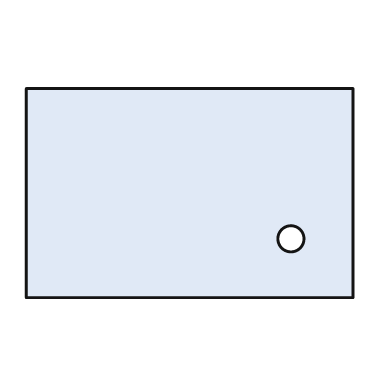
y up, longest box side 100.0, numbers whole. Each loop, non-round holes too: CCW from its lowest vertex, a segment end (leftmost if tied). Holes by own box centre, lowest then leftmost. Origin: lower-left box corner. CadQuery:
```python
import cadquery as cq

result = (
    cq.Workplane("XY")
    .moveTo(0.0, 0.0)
    .lineTo(100.0, 0.0)
    .lineTo(100.0, 64.0)
    .lineTo(0.0, 64.0)
    .close()
    .moveTo(81.0, 18.0)
    .circle(4.0)
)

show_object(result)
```